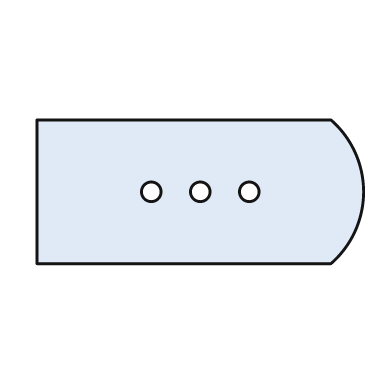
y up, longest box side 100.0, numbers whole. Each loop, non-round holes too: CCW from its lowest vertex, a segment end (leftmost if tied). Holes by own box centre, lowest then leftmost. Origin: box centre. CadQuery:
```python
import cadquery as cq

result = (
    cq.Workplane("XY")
    .moveTo(-50.0, -22.0)
    .lineTo(40.0, -22.0)
    .threePointArc((50.0, 0.0), (40.0, 22.0))
    .lineTo(-50.0, 22.0)
    .close()
    .moveTo(-15.0, 0.0)
    .circle(3.0)
    .moveTo(0.0, 0.0)
    .circle(3.0)
    .moveTo(15.0, 0.0)
    .circle(3.0)
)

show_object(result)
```